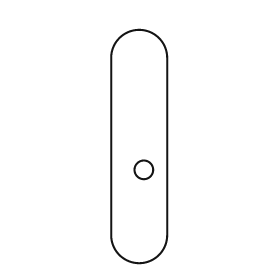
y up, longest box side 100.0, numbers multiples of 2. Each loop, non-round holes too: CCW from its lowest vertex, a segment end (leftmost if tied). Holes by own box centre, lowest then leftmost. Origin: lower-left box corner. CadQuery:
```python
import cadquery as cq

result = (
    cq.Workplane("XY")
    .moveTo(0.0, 12.0)
    .threePointArc((12.0, 0.0), (24.0, 12.0))
    .lineTo(24.0, 88.0)
    .threePointArc((12.0, 100.0), (0.0, 88.0))
    .close()
    .moveTo(14.0, 40.0)
    .circle(4.0)
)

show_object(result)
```